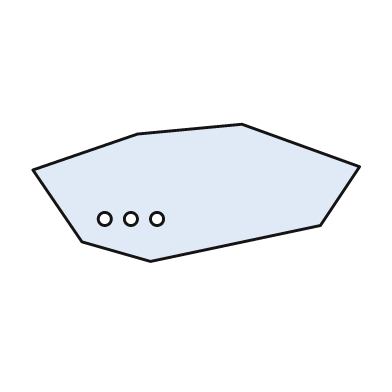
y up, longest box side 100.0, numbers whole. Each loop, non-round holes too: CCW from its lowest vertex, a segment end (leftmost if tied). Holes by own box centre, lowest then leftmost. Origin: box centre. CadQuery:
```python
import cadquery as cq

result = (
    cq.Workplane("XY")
    .moveTo(-14.0, -21.0)
    .lineTo(38.0, -10.0)
    .lineTo(50.0, 8.0)
    .lineTo(14.0, 21.0)
    .lineTo(-18.0, 18.0)
    .lineTo(-50.0, 7.0)
    .lineTo(-35.0, -15.0)
    .close()
    .moveTo(-28.0, -8.0)
    .circle(2.0)
    .moveTo(-20.0, -8.0)
    .circle(2.0)
    .moveTo(-12.0, -8.0)
    .circle(2.0)
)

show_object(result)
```